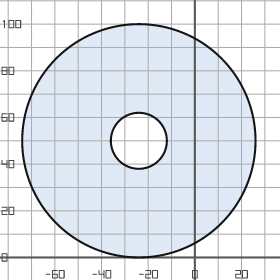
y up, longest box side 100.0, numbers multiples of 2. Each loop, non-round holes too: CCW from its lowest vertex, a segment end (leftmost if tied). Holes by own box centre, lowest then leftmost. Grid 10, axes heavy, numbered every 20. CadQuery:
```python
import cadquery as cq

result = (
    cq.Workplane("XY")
    .moveTo(-24.0, 50.0)
    .circle(50.0)
    .moveTo(-24.0, 50.0)
    .circle(12.0)
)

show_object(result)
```